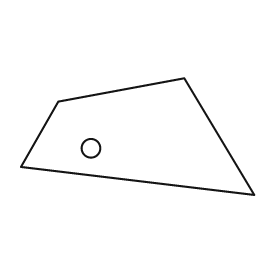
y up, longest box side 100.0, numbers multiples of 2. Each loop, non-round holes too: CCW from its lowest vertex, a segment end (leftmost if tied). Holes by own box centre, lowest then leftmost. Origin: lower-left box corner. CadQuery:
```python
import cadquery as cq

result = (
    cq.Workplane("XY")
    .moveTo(100.0, 0.0)
    .lineTo(70.0, 50.0)
    .lineTo(16.0, 40.0)
    .lineTo(0.0, 12.0)
    .close()
    .moveTo(30.0, 20.0)
    .circle(4.0)
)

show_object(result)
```